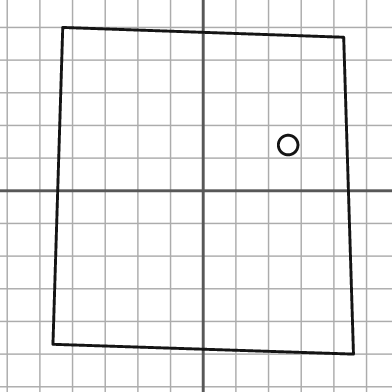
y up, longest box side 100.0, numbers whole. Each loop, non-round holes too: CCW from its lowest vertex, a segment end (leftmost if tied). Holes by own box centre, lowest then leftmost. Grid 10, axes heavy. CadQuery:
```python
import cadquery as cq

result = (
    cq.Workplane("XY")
    .moveTo(46.0, -50.0)
    .lineTo(43.0, 47.0)
    .lineTo(-43.0, 50.0)
    .lineTo(-46.0, -47.0)
    .close()
    .moveTo(26.0, 14.0)
    .circle(3.0)
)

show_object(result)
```